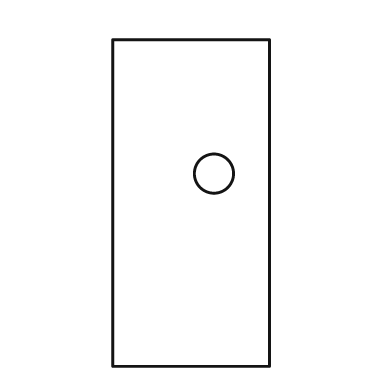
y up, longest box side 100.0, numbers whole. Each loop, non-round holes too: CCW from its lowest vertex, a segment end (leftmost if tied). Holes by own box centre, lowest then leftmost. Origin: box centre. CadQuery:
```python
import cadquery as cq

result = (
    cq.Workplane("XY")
    .moveTo(-24.0, -50.0)
    .lineTo(24.0, -50.0)
    .lineTo(24.0, 50.0)
    .lineTo(-24.0, 50.0)
    .close()
    .moveTo(7.0, 9.0)
    .circle(6.0)
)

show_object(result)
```